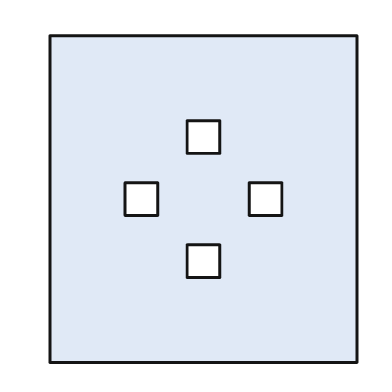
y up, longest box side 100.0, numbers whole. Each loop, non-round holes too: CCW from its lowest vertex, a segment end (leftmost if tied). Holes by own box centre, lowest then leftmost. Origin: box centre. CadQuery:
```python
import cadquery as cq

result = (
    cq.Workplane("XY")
    .moveTo(-47.0, -50.0)
    .lineTo(47.0, -50.0)
    .lineTo(47.0, 50.0)
    .lineTo(-47.0, 50.0)
    .close()
    .moveTo(-5.0, -24.0)
    .lineTo(5.0, -24.0)
    .lineTo(5.0, -14.0)
    .lineTo(-5.0, -14.0)
    .close()
    .moveTo(-24.0, -5.0)
    .lineTo(-14.0, -5.0)
    .lineTo(-14.0, 5.0)
    .lineTo(-24.0, 5.0)
    .close()
    .moveTo(14.0, -5.0)
    .lineTo(24.0, -5.0)
    .lineTo(24.0, 5.0)
    .lineTo(14.0, 5.0)
    .close()
    .moveTo(-5.0, 14.0)
    .lineTo(5.0, 14.0)
    .lineTo(5.0, 24.0)
    .lineTo(-5.0, 24.0)
    .close()
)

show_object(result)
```